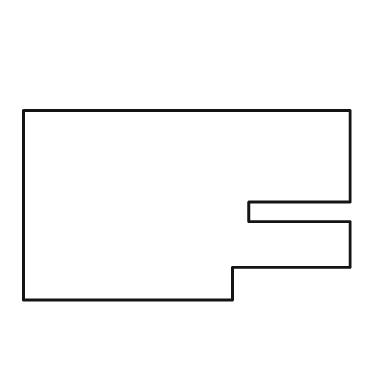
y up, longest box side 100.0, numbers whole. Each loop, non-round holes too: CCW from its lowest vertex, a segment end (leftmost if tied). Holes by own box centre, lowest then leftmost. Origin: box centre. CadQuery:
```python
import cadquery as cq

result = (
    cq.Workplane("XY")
    .moveTo(-50.0, -29.0)
    .lineTo(14.0, -29.0)
    .lineTo(14.0, -19.0)
    .lineTo(50.0, -19.0)
    .lineTo(50.0, -5.0)
    .lineTo(19.0, -5.0)
    .lineTo(19.0, 1.0)
    .lineTo(50.0, 1.0)
    .lineTo(50.0, 29.0)
    .lineTo(-50.0, 29.0)
    .close()
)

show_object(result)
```